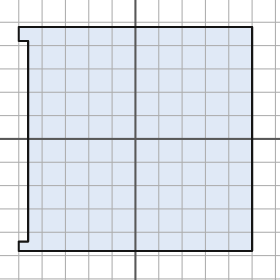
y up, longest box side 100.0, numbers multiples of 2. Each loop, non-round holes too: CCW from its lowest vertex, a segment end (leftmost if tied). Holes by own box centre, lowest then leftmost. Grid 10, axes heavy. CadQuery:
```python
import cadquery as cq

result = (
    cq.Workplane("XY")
    .moveTo(-50.0, -48.0)
    .lineTo(50.0, -48.0)
    .lineTo(50.0, 48.0)
    .lineTo(-50.0, 48.0)
    .lineTo(-50.0, 42.0)
    .lineTo(-46.0, 42.0)
    .lineTo(-46.0, -44.0)
    .lineTo(-50.0, -44.0)
    .close()
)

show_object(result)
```